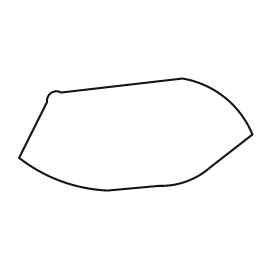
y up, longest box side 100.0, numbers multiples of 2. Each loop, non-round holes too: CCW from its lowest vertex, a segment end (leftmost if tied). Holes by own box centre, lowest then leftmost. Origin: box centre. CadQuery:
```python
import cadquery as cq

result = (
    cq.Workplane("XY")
    .moveTo(-12.0, -24.0)
    .lineTo(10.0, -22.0)
    .threePointArc((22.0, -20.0), (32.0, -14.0))
    .lineTo(50.0, 0.0)
    .threePointArc((38.0, 16.0), (20.0, 24.0))
    .lineTo(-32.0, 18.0)
    .threePointArc((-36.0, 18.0), (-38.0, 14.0))
    .lineTo(-50.0, -10.0)
    .threePointArc((-32.0, -20.0), (-12.0, -24.0))
    .close()
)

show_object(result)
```